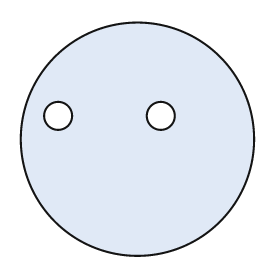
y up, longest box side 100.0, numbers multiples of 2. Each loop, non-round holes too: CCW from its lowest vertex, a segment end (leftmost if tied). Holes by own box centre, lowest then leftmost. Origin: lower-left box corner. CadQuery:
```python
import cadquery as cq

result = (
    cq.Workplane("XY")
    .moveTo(50.0, 50.0)
    .circle(50.0)
    .moveTo(16.0, 60.0)
    .circle(6.0)
    .moveTo(60.0, 60.0)
    .circle(6.0)
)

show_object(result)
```